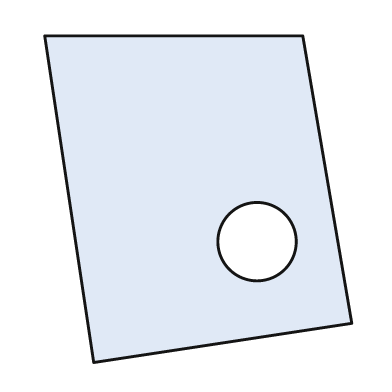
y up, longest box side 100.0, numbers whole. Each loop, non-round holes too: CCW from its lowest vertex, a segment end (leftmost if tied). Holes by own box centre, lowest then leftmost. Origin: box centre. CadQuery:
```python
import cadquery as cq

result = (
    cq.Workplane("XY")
    .moveTo(-32.0, -50.0)
    .lineTo(47.0, -38.0)
    .lineTo(32.0, 50.0)
    .lineTo(-47.0, 50.0)
    .close()
    .moveTo(18.0, -13.0)
    .circle(12.0)
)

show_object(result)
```